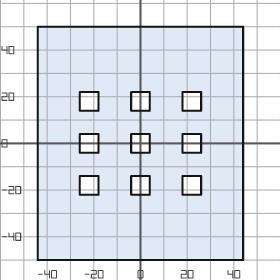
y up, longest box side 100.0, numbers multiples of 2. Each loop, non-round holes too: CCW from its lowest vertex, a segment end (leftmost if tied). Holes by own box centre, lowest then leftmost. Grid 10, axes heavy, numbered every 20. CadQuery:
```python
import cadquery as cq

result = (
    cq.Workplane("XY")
    .moveTo(-44.0, -50.0)
    .lineTo(44.0, -50.0)
    .lineTo(44.0, 50.0)
    .lineTo(-44.0, 50.0)
    .close()
    .moveTo(-26.0, -22.0)
    .lineTo(-18.0, -22.0)
    .lineTo(-18.0, -14.0)
    .lineTo(-26.0, -14.0)
    .close()
    .moveTo(-4.0, -22.0)
    .lineTo(4.0, -22.0)
    .lineTo(4.0, -14.0)
    .lineTo(-4.0, -14.0)
    .close()
    .moveTo(18.0, -22.0)
    .lineTo(26.0, -22.0)
    .lineTo(26.0, -14.0)
    .lineTo(18.0, -14.0)
    .close()
    .moveTo(-26.0, -4.0)
    .lineTo(-18.0, -4.0)
    .lineTo(-18.0, 4.0)
    .lineTo(-26.0, 4.0)
    .close()
    .moveTo(-4.0, -4.0)
    .lineTo(4.0, -4.0)
    .lineTo(4.0, 4.0)
    .lineTo(-4.0, 4.0)
    .close()
    .moveTo(18.0, -4.0)
    .lineTo(26.0, -4.0)
    .lineTo(26.0, 4.0)
    .lineTo(18.0, 4.0)
    .close()
    .moveTo(-26.0, 14.0)
    .lineTo(-18.0, 14.0)
    .lineTo(-18.0, 22.0)
    .lineTo(-26.0, 22.0)
    .close()
    .moveTo(-4.0, 14.0)
    .lineTo(4.0, 14.0)
    .lineTo(4.0, 22.0)
    .lineTo(-4.0, 22.0)
    .close()
    .moveTo(18.0, 14.0)
    .lineTo(26.0, 14.0)
    .lineTo(26.0, 22.0)
    .lineTo(18.0, 22.0)
    .close()
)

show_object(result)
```